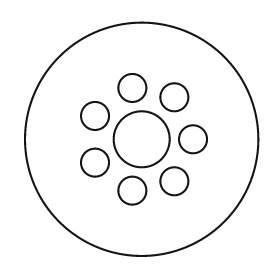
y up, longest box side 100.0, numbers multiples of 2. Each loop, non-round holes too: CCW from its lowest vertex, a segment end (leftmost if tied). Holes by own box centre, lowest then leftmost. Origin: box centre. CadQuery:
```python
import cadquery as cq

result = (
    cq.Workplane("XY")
    .moveTo(0.0, 0.0)
    .circle(50.0)
    .moveTo(-4.0, -22.0)
    .circle(6.0)
    .moveTo(14.0, -18.0)
    .circle(6.0)
    .moveTo(-20.0, -10.0)
    .circle(6.0)
    .moveTo(0.0, 0.0)
    .circle(12.0)
    .moveTo(22.0, 0.0)
    .circle(6.0)
    .moveTo(-20.0, 10.0)
    .circle(6.0)
    .moveTo(14.0, 18.0)
    .circle(6.0)
    .moveTo(-4.0, 22.0)
    .circle(6.0)
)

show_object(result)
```